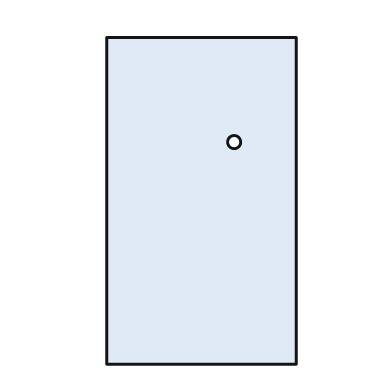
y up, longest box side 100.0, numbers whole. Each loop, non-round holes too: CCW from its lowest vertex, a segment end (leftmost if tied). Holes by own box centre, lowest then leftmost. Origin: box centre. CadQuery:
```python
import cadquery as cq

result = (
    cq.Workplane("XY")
    .moveTo(-29.0, -50.0)
    .lineTo(29.0, -50.0)
    .lineTo(29.0, 50.0)
    .lineTo(-29.0, 50.0)
    .close()
    .moveTo(10.0, 18.0)
    .circle(2.0)
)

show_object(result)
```